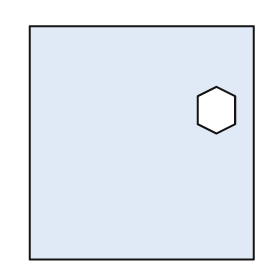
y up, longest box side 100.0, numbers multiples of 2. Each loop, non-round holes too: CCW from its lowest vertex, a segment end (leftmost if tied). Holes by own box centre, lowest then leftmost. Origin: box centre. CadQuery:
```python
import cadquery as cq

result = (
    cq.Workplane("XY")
    .moveTo(-48.0, -50.0)
    .lineTo(48.0, -50.0)
    .lineTo(48.0, 50.0)
    .lineTo(-48.0, 50.0)
    .close()
    .moveTo(32.0, 4.0)
    .lineTo(40.0, 8.0)
    .lineTo(40.0, 20.0)
    .lineTo(32.0, 24.0)
    .lineTo(24.0, 20.0)
    .lineTo(24.0, 8.0)
    .close()
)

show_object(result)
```